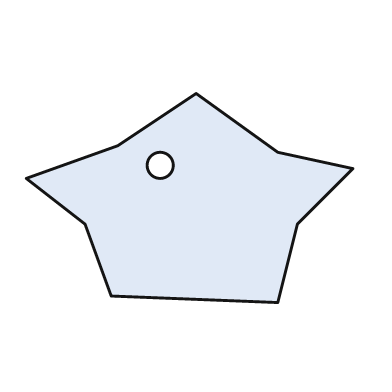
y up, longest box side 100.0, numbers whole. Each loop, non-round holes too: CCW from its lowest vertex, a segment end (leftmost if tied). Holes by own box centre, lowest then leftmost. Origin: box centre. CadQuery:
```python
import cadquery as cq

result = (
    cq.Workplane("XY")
    .moveTo(27.0, -32.0)
    .lineTo(33.0, -8.0)
    .lineTo(50.0, 9.0)
    .lineTo(27.0, 14.0)
    .lineTo(2.0, 32.0)
    .lineTo(-22.0, 16.0)
    .lineTo(-50.0, 6.0)
    .lineTo(-32.0, -8.0)
    .lineTo(-24.0, -30.0)
    .close()
    .moveTo(-9.0, 10.0)
    .circle(4.0)
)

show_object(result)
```